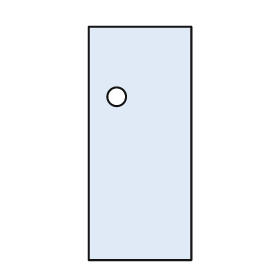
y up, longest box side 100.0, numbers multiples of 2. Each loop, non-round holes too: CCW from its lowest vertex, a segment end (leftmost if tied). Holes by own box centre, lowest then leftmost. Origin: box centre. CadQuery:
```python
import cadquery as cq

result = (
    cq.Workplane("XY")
    .moveTo(-22.0, -50.0)
    .lineTo(22.0, -50.0)
    .lineTo(22.0, 50.0)
    .lineTo(-22.0, 50.0)
    .close()
    .moveTo(-10.0, 20.0)
    .circle(4.0)
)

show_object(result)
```